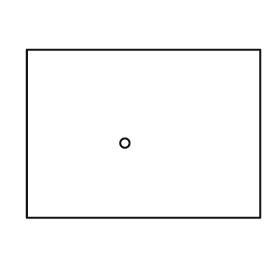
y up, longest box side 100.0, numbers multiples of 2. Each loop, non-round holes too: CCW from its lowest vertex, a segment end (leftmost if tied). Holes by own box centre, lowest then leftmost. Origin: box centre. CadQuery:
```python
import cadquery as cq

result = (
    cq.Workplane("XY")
    .moveTo(-50.0, -36.0)
    .lineTo(50.0, -36.0)
    .lineTo(50.0, 36.0)
    .lineTo(-50.0, 36.0)
    .close()
    .moveTo(-8.0, -4.0)
    .circle(2.0)
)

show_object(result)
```